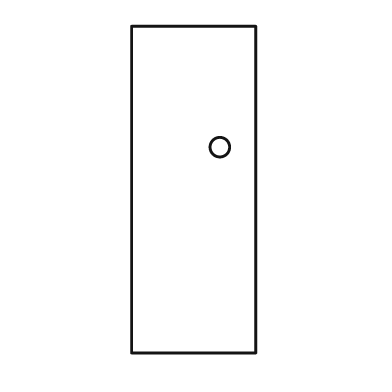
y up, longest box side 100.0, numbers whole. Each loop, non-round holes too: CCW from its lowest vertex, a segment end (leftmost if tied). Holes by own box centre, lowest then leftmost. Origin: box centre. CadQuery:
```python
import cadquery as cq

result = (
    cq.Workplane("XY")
    .moveTo(-19.0, -50.0)
    .lineTo(19.0, -50.0)
    .lineTo(19.0, 50.0)
    .lineTo(-19.0, 50.0)
    .close()
    .moveTo(8.0, 13.0)
    .circle(3.0)
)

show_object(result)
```